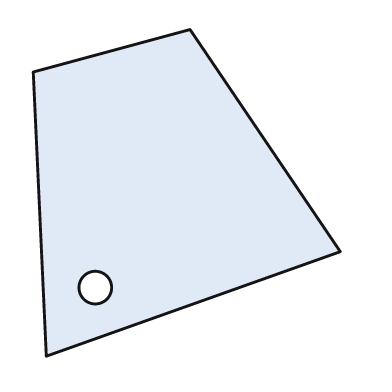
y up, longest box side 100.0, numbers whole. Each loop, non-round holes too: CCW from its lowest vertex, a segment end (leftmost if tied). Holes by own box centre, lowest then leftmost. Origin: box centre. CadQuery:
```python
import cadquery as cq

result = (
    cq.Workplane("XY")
    .moveTo(-43.0, -50.0)
    .lineTo(47.0, -18.0)
    .lineTo(1.0, 50.0)
    .lineTo(-47.0, 37.0)
    .close()
    .moveTo(-28.0, -29.0)
    .circle(5.0)
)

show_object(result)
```